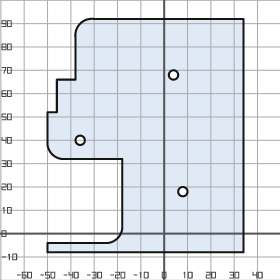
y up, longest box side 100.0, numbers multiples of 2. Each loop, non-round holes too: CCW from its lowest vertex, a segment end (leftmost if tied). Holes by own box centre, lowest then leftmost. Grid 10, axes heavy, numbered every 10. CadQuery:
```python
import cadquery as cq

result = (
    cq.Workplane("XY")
    .moveTo(-50.0, -8.0)
    .lineTo(34.0, -8.0)
    .lineTo(34.0, 92.0)
    .lineTo(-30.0, 92.0)
    .threePointArc((-36.0, 90.0), (-38.0, 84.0))
    .lineTo(-38.0, 66.0)
    .lineTo(-46.0, 66.0)
    .lineTo(-46.0, 52.0)
    .lineTo(-50.0, 52.0)
    .lineTo(-50.0, 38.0)
    .threePointArc((-48.0, 34.0), (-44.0, 32.0))
    .lineTo(-18.0, 32.0)
    .lineTo(-18.0, 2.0)
    .threePointArc((-20.0, -2.0), (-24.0, -4.0))
    .lineTo(-50.0, -4.0)
    .close()
    .moveTo(8.0, 18.0)
    .circle(2.0)
    .moveTo(-36.0, 40.0)
    .circle(2.0)
    .moveTo(4.0, 68.0)
    .circle(2.0)
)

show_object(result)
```